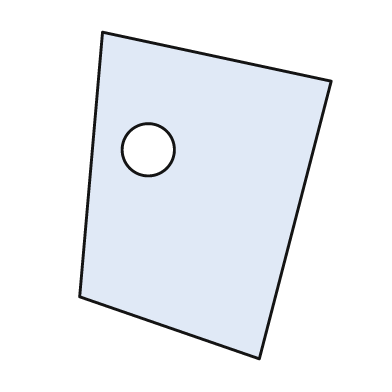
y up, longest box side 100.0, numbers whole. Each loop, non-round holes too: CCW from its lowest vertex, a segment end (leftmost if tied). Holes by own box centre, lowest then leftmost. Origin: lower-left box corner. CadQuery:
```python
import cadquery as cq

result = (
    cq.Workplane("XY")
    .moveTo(55.0, 0.0)
    .lineTo(77.0, 85.0)
    .lineTo(7.0, 100.0)
    .lineTo(0.0, 19.0)
    .close()
    .moveTo(21.0, 64.0)
    .circle(8.0)
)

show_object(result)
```